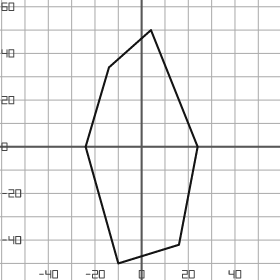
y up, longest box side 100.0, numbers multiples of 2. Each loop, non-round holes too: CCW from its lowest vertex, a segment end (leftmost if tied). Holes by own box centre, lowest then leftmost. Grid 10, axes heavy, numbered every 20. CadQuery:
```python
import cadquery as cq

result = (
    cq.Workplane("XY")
    .moveTo(-10.0, -50.0)
    .lineTo(16.0, -42.0)
    .lineTo(24.0, 0.0)
    .lineTo(4.0, 50.0)
    .lineTo(-14.0, 34.0)
    .lineTo(-24.0, 0.0)
    .close()
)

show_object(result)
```